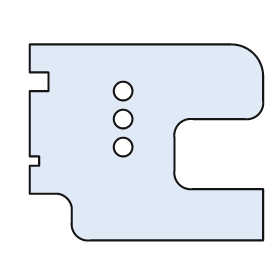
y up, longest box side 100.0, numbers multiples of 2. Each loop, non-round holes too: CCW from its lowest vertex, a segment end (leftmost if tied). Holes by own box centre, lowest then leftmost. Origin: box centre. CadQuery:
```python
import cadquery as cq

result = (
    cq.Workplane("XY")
    .moveTo(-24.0, -42.0)
    .lineTo(50.0, -42.0)
    .lineTo(50.0, -20.0)
    .lineTo(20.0, -20.0)
    .threePointArc((14.0, -18.0), (12.0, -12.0))
    .lineTo(12.0, 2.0)
    .threePointArc((14.0, 8.0), (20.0, 10.0))
    .lineTo(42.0, 10.0)
    .threePointArc((48.0, 12.0), (50.0, 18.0))
    .lineTo(50.0, 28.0)
    .threePointArc((46.0, 38.0), (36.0, 42.0))
    .lineTo(-50.0, 42.0)
    .lineTo(-50.0, 30.0)
    .lineTo(-42.0, 30.0)
    .lineTo(-42.0, 22.0)
    .lineTo(-50.0, 22.0)
    .lineTo(-50.0, -6.0)
    .lineTo(-46.0, -6.0)
    .lineTo(-46.0, -10.0)
    .lineTo(-50.0, -10.0)
    .lineTo(-50.0, -22.0)
    .lineTo(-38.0, -22.0)
    .threePointArc((-34.0, -24.0), (-32.0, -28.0))
    .lineTo(-32.0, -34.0)
    .threePointArc((-30.0, -40.0), (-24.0, -42.0))
    .close()
    .moveTo(-10.0, -2.0)
    .circle(4.0)
    .moveTo(-10.0, 10.0)
    .circle(4.0)
    .moveTo(-10.0, 22.0)
    .circle(4.0)
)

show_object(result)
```